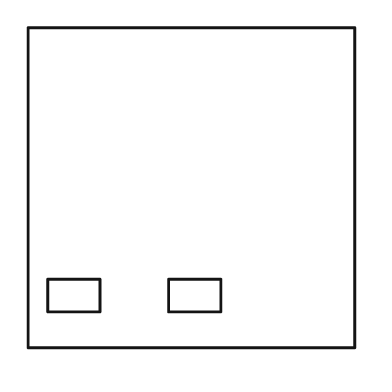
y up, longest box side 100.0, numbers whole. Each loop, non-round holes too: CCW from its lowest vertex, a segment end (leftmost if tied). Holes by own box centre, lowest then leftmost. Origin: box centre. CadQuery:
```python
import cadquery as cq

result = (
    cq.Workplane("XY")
    .moveTo(-50.0, -49.0)
    .lineTo(50.0, -49.0)
    .lineTo(50.0, 49.0)
    .lineTo(-50.0, 49.0)
    .close()
    .moveTo(-44.0, -38.0)
    .lineTo(-28.0, -38.0)
    .lineTo(-28.0, -28.0)
    .lineTo(-44.0, -28.0)
    .close()
    .moveTo(-7.0, -38.0)
    .lineTo(9.0, -38.0)
    .lineTo(9.0, -28.0)
    .lineTo(-7.0, -28.0)
    .close()
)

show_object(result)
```